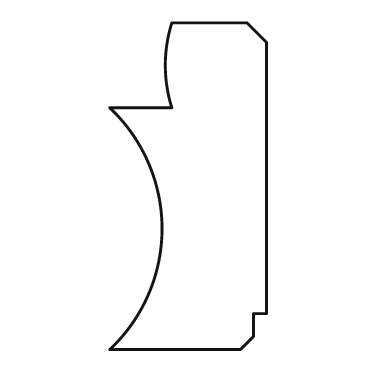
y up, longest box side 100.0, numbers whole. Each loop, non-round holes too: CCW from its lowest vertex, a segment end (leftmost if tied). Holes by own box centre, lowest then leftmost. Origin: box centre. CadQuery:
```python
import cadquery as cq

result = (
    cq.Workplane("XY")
    .moveTo(-24.0, -50.0)
    .lineTo(16.0, -50.0)
    .lineTo(20.0, -46.0)
    .lineTo(20.0, -39.0)
    .lineTo(24.0, -39.0)
    .lineTo(24.0, 44.0)
    .lineTo(18.0, 50.0)
    .lineTo(-5.0, 50.0)
    .threePointArc((-7.0, 37.0), (-5.0, 24.0))
    .lineTo(-24.0, 24.0)
    .threePointArc((-8.0, -13.0), (-24.0, -50.0))
    .close()
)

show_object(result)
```